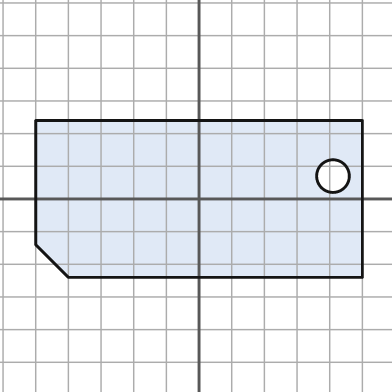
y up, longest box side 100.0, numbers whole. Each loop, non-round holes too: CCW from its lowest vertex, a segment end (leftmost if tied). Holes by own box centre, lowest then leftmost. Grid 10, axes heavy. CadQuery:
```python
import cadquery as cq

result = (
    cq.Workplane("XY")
    .moveTo(-40.0, -24.0)
    .lineTo(50.0, -24.0)
    .lineTo(50.0, 24.0)
    .lineTo(-50.0, 24.0)
    .lineTo(-50.0, -14.0)
    .close()
    .moveTo(41.0, 7.0)
    .circle(5.0)
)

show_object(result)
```